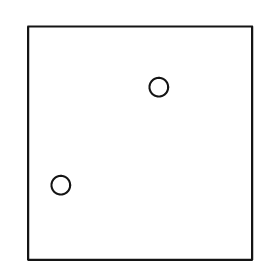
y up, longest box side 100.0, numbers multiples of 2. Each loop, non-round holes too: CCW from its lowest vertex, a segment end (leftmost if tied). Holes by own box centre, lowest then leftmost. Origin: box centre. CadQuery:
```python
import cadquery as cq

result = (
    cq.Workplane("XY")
    .moveTo(-48.0, -50.0)
    .lineTo(48.0, -50.0)
    .lineTo(48.0, 50.0)
    .lineTo(-48.0, 50.0)
    .close()
    .moveTo(-34.0, -18.0)
    .circle(4.0)
    .moveTo(8.0, 24.0)
    .circle(4.0)
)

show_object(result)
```